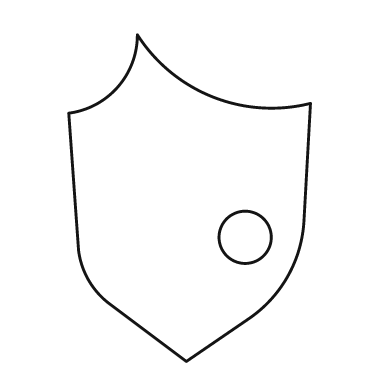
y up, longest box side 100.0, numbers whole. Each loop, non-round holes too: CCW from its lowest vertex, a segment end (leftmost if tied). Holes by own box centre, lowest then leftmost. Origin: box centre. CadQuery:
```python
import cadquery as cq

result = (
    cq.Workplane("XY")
    .moveTo(-1.0, -50.0)
    .lineTo(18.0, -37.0)
    .threePointArc((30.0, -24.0), (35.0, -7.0))
    .lineTo(37.0, 29.0)
    .threePointArc((7.0, 31.0), (-16.0, 50.0))
    .threePointArc((-22.0, 34.0), (-37.0, 26.0))
    .lineTo(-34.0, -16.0)
    .threePointArc((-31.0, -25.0), (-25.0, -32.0))
    .close()
    .moveTo(17.0, -12.0)
    .circle(8.0)
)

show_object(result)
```